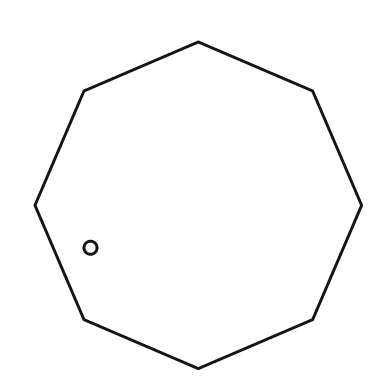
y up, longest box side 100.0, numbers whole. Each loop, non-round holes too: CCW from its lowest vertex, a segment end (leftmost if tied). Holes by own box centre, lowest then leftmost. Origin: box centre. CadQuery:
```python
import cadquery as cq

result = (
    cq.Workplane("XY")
    .moveTo(0.0, -50.0)
    .lineTo(35.0, -35.0)
    .lineTo(50.0, 0.0)
    .lineTo(35.0, 35.0)
    .lineTo(0.0, 50.0)
    .lineTo(-35.0, 35.0)
    .lineTo(-50.0, 0.0)
    .lineTo(-35.0, -35.0)
    .close()
    .moveTo(-33.0, -13.0)
    .circle(2.0)
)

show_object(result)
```